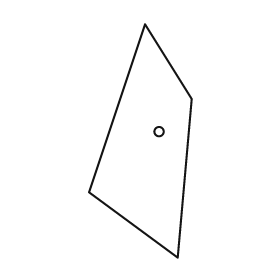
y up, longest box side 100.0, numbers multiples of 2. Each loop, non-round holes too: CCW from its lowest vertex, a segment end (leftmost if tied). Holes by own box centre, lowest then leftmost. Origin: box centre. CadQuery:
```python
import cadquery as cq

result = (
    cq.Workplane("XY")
    .moveTo(16.0, -50.0)
    .lineTo(22.0, 18.0)
    .lineTo(2.0, 50.0)
    .lineTo(-22.0, -22.0)
    .close()
    .moveTo(8.0, 4.0)
    .circle(2.0)
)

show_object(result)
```